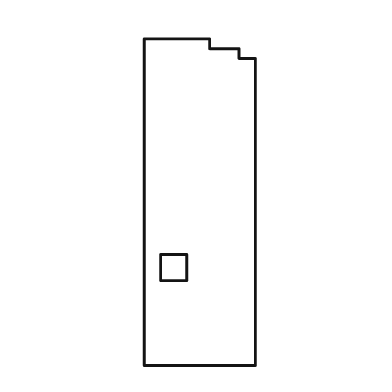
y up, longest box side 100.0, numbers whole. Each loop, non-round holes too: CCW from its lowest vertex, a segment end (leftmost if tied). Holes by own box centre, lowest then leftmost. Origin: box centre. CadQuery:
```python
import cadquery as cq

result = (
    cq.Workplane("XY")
    .moveTo(-17.0, -50.0)
    .lineTo(17.0, -50.0)
    .lineTo(17.0, 44.0)
    .lineTo(12.0, 44.0)
    .lineTo(12.0, 47.0)
    .lineTo(3.0, 47.0)
    .lineTo(3.0, 50.0)
    .lineTo(-17.0, 50.0)
    .close()
    .moveTo(-12.0, -24.0)
    .lineTo(-4.0, -24.0)
    .lineTo(-4.0, -16.0)
    .lineTo(-12.0, -16.0)
    .close()
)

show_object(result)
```